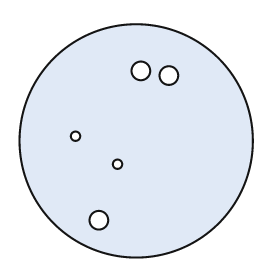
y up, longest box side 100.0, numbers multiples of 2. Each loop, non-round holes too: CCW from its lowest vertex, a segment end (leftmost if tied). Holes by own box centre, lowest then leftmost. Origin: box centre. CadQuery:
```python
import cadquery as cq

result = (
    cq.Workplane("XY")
    .moveTo(0.0, 0.0)
    .circle(50.0)
    .moveTo(-16.0, -34.0)
    .circle(4.0)
    .moveTo(-8.0, -10.0)
    .circle(2.0)
    .moveTo(-26.0, 2.0)
    .circle(2.0)
    .moveTo(14.0, 28.0)
    .circle(4.0)
    .moveTo(2.0, 30.0)
    .circle(4.0)
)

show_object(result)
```